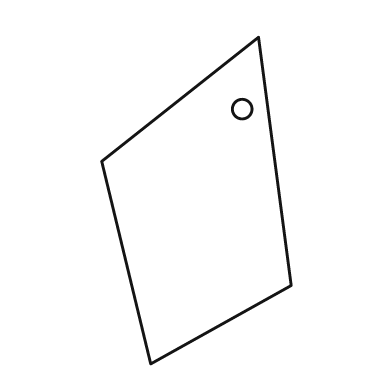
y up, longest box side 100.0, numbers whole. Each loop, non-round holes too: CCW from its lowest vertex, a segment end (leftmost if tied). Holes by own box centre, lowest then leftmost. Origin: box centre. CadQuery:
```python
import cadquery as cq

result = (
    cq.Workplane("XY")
    .moveTo(-14.0, -50.0)
    .lineTo(29.0, -26.0)
    .lineTo(19.0, 50.0)
    .lineTo(-29.0, 12.0)
    .close()
    .moveTo(14.0, 28.0)
    .circle(3.0)
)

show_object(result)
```